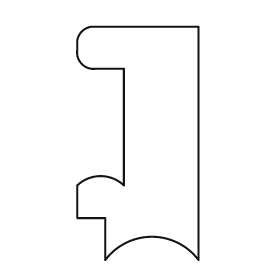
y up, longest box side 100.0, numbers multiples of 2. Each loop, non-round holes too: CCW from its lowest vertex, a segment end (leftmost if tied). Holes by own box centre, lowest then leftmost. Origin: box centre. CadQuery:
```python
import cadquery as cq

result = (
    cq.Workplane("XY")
    .moveTo(-14.0, -50.0)
    .threePointArc((6.0, -40.0), (26.0, -50.0))
    .lineTo(26.0, 50.0)
    .lineTo(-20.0, 50.0)
    .threePointArc((-24.0, 48.0), (-26.0, 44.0))
    .lineTo(-26.0, 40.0)
    .threePointArc((-24.0, 34.0), (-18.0, 32.0))
    .lineTo(-6.0, 32.0)
    .lineTo(-6.0, -18.0)
    .threePointArc((-16.0, -14.0), (-26.0, -18.0))
    .lineTo(-26.0, -32.0)
    .lineTo(-14.0, -32.0)
    .close()
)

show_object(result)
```